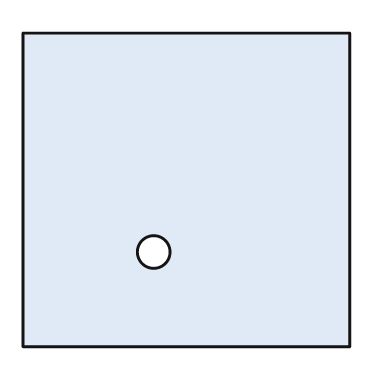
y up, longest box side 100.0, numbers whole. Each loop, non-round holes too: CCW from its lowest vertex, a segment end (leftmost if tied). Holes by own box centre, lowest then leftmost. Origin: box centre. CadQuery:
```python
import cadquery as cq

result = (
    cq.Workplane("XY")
    .moveTo(-50.0, -48.0)
    .lineTo(50.0, -48.0)
    .lineTo(50.0, 48.0)
    .lineTo(-50.0, 48.0)
    .close()
    .moveTo(-10.0, -19.0)
    .circle(5.0)
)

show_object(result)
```